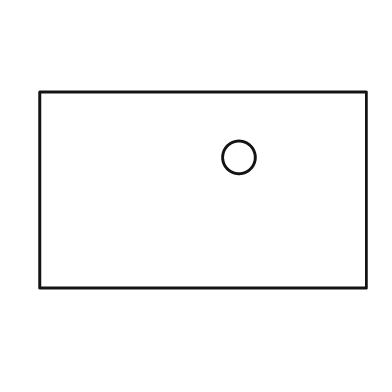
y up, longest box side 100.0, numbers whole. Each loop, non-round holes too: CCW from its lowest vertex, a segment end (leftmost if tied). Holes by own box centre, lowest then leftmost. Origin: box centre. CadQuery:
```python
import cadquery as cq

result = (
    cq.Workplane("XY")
    .moveTo(-50.0, -30.0)
    .lineTo(50.0, -30.0)
    .lineTo(50.0, 30.0)
    .lineTo(-50.0, 30.0)
    .close()
    .moveTo(11.0, 10.0)
    .circle(5.0)
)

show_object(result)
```